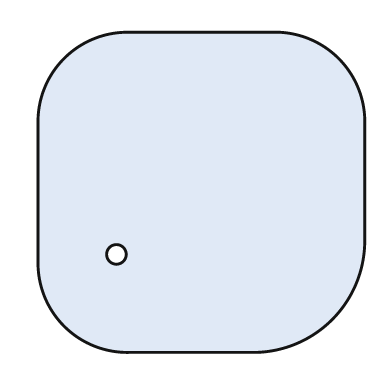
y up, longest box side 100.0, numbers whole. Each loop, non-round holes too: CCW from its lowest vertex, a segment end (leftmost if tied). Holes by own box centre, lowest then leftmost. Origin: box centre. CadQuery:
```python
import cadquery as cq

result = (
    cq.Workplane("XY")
    .moveTo(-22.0, -49.0)
    .lineTo(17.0, -49.0)
    .threePointArc((40.0, -39.0), (50.0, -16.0))
    .lineTo(50.0, 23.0)
    .threePointArc((42.0, 41.0), (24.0, 49.0))
    .lineTo(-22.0, 49.0)
    .threePointArc((-42.0, 41.0), (-50.0, 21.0))
    .lineTo(-50.0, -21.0)
    .threePointArc((-42.0, -41.0), (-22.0, -49.0))
    .close()
    .moveTo(-26.0, -19.0)
    .circle(3.0)
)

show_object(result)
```